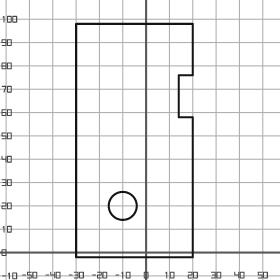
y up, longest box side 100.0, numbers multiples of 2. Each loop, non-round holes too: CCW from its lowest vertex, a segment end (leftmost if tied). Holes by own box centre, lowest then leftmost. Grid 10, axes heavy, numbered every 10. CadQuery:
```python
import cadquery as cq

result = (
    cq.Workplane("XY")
    .moveTo(-30.0, -2.0)
    .lineTo(20.0, -2.0)
    .lineTo(20.0, 58.0)
    .lineTo(14.0, 58.0)
    .lineTo(14.0, 76.0)
    .lineTo(20.0, 76.0)
    .lineTo(20.0, 98.0)
    .lineTo(-30.0, 98.0)
    .close()
    .moveTo(-10.0, 20.0)
    .circle(6.0)
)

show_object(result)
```